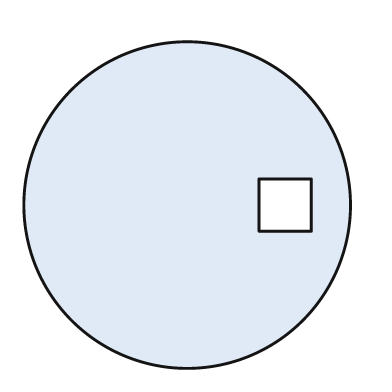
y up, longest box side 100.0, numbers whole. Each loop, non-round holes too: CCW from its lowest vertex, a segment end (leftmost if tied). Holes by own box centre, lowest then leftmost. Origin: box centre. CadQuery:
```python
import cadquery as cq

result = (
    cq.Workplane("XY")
    .moveTo(0.0, 0.0)
    .circle(50.0)
    .moveTo(22.0, -8.0)
    .lineTo(38.0, -8.0)
    .lineTo(38.0, 8.0)
    .lineTo(22.0, 8.0)
    .close()
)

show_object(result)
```